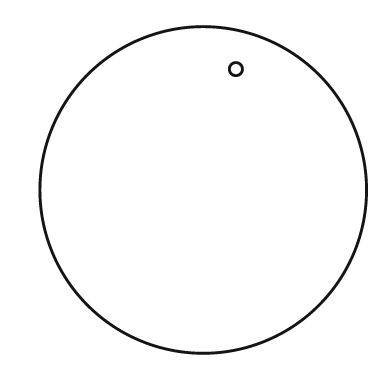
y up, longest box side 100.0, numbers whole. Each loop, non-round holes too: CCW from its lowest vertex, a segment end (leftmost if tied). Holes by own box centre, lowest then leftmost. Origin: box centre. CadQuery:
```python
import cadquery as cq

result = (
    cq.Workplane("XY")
    .moveTo(0.0, 0.0)
    .circle(50.0)
    .moveTo(10.0, 37.0)
    .circle(2.0)
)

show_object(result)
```